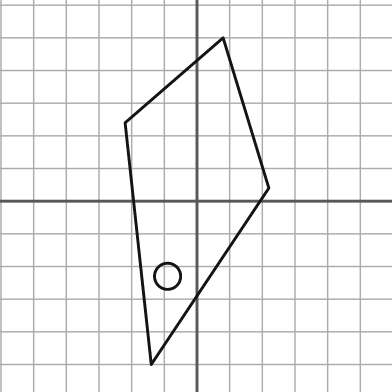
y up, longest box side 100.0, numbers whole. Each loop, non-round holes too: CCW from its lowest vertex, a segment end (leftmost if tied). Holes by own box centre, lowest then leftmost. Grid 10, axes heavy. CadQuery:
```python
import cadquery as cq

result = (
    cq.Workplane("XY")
    .moveTo(-14.0, -50.0)
    .lineTo(22.0, 4.0)
    .lineTo(8.0, 50.0)
    .lineTo(-22.0, 24.0)
    .close()
    .moveTo(-9.0, -23.0)
    .circle(4.0)
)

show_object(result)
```